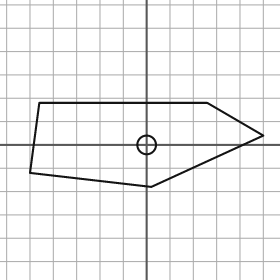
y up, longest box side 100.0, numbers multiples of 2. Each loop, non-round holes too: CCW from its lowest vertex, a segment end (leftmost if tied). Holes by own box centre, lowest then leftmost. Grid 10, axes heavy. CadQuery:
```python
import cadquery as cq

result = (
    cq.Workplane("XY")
    .moveTo(2.0, -18.0)
    .lineTo(50.0, 4.0)
    .lineTo(26.0, 18.0)
    .lineTo(-46.0, 18.0)
    .lineTo(-50.0, -12.0)
    .close()
    .moveTo(0.0, 0.0)
    .circle(4.0)
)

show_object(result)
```